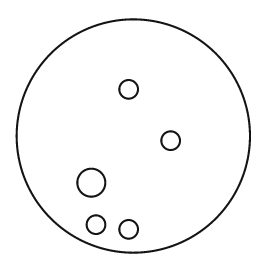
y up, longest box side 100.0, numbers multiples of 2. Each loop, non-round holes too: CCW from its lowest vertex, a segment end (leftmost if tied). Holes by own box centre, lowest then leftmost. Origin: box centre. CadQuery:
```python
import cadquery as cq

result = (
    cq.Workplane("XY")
    .moveTo(0.0, 0.0)
    .circle(50.0)
    .moveTo(-2.0, -40.0)
    .circle(4.0)
    .moveTo(-16.0, -38.0)
    .circle(4.0)
    .moveTo(-18.0, -20.0)
    .circle(6.0)
    .moveTo(16.0, -2.0)
    .circle(4.0)
    .moveTo(-2.0, 20.0)
    .circle(4.0)
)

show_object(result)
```